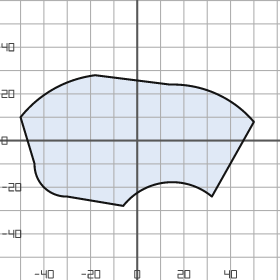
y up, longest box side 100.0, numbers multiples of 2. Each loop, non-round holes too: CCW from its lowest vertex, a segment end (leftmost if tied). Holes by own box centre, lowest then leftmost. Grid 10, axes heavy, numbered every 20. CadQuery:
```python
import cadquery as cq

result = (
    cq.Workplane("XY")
    .moveTo(-6.0, -28.0)
    .threePointArc((12.0, -18.0), (32.0, -24.0))
    .lineTo(50.0, 8.0)
    .threePointArc((34.0, 20.0), (14.0, 24.0))
    .lineTo(-18.0, 28.0)
    .threePointArc((-36.0, 22.0), (-50.0, 10.0))
    .lineTo(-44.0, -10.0)
    .threePointArc((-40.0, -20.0), (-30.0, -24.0))
    .close()
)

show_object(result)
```